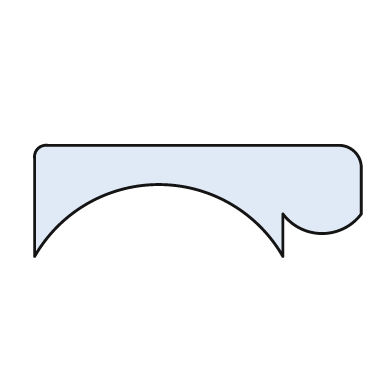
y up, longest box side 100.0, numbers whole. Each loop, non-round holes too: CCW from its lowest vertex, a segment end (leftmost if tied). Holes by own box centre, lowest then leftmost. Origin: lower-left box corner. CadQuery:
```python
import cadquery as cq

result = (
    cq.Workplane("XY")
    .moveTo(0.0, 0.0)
    .threePointArc((38.0, 22.0), (76.0, 0.0))
    .lineTo(76.0, 13.0)
    .threePointArc((88.0, 7.0), (100.0, 13.0))
    .lineTo(100.0, 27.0)
    .threePointArc((98.0, 32.0), (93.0, 34.0))
    .lineTo(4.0, 34.0)
    .threePointArc((1.0, 33.0), (0.0, 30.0))
    .close()
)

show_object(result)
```